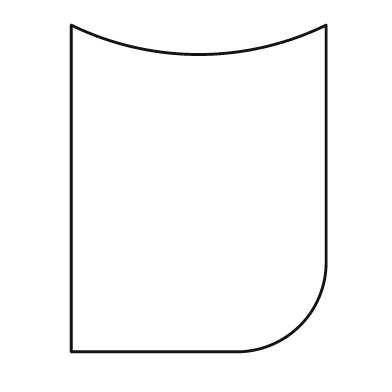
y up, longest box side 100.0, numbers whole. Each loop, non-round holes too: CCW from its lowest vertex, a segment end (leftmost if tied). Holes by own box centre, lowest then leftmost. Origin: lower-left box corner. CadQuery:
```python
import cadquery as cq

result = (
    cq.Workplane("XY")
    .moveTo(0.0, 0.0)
    .lineTo(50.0, 0.0)
    .threePointArc((70.0, 8.0), (78.0, 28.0))
    .lineTo(78.0, 100.0)
    .threePointArc((39.0, 91.0), (0.0, 100.0))
    .close()
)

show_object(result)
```